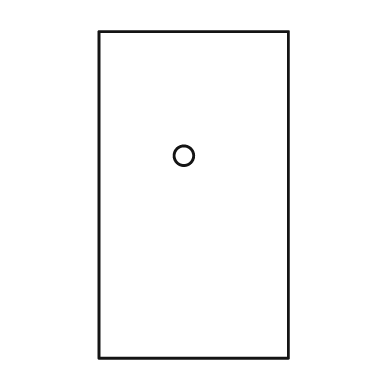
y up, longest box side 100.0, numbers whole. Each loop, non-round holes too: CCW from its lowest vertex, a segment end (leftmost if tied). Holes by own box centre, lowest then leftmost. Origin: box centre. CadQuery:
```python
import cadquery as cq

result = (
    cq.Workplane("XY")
    .moveTo(-29.0, -50.0)
    .lineTo(29.0, -50.0)
    .lineTo(29.0, 50.0)
    .lineTo(-29.0, 50.0)
    .close()
    .moveTo(-3.0, 12.0)
    .circle(3.0)
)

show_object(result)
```